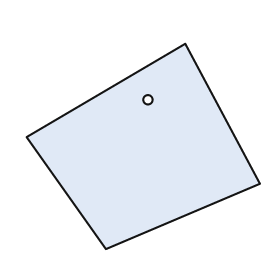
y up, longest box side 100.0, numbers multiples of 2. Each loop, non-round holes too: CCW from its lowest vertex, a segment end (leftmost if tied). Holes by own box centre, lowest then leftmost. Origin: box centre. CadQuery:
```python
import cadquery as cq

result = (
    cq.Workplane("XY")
    .moveTo(-16.0, -44.0)
    .lineTo(50.0, -16.0)
    .lineTo(18.0, 44.0)
    .lineTo(-50.0, 4.0)
    .close()
    .moveTo(2.0, 20.0)
    .circle(2.0)
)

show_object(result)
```